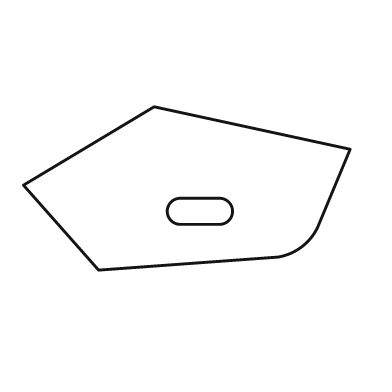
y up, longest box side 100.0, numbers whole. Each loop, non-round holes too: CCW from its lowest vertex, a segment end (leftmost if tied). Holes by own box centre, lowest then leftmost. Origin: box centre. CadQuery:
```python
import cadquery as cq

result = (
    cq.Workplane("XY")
    .moveTo(-27.0, -25.0)
    .lineTo(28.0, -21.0)
    .threePointArc((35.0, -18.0), (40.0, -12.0))
    .lineTo(50.0, 12.0)
    .lineTo(-10.0, 25.0)
    .lineTo(-50.0, 1.0)
    .close()
    .moveTo(-2.0, -11.0)
    .lineTo(10.0, -11.0)
    .threePointArc((14.0, -7.0), (10.0, -3.0))
    .lineTo(-2.0, -3.0)
    .threePointArc((-6.0, -7.0), (-2.0, -11.0))
    .close()
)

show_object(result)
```